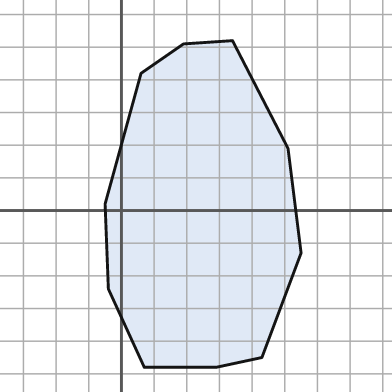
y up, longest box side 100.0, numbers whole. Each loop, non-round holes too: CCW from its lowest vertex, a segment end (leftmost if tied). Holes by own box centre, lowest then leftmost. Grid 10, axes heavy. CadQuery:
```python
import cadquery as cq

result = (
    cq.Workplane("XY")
    .moveTo(7.0, -48.0)
    .lineTo(29.0, -48.0)
    .lineTo(43.0, -45.0)
    .lineTo(55.0, -13.0)
    .lineTo(51.0, 19.0)
    .lineTo(34.0, 52.0)
    .lineTo(19.0, 51.0)
    .lineTo(6.0, 42.0)
    .lineTo(-5.0, 2.0)
    .lineTo(-4.0, -24.0)
    .close()
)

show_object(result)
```